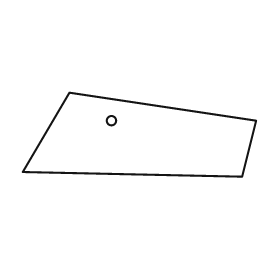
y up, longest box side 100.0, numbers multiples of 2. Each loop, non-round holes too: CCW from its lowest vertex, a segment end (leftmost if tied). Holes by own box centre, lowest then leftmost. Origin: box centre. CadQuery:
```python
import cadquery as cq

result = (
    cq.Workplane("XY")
    .moveTo(44.0, -18.0)
    .lineTo(50.0, 6.0)
    .lineTo(-30.0, 18.0)
    .lineTo(-50.0, -16.0)
    .close()
    .moveTo(-12.0, 6.0)
    .circle(2.0)
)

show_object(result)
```